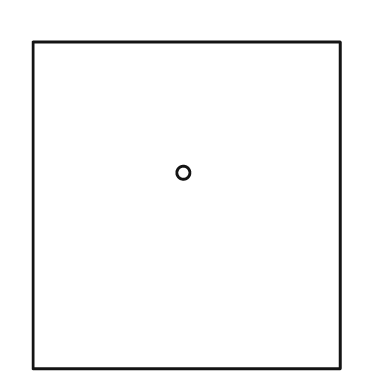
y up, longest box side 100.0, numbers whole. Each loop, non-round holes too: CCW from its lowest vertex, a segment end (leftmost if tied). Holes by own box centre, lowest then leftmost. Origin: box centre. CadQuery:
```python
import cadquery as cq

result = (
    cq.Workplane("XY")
    .moveTo(-47.0, -50.0)
    .lineTo(47.0, -50.0)
    .lineTo(47.0, 50.0)
    .lineTo(-47.0, 50.0)
    .close()
    .moveTo(-1.0, 10.0)
    .circle(2.0)
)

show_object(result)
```